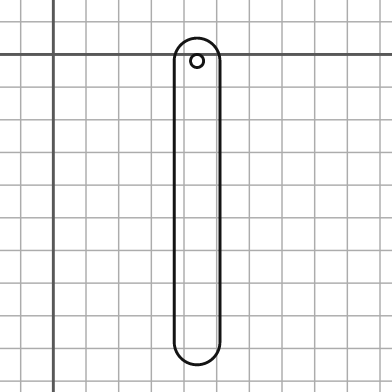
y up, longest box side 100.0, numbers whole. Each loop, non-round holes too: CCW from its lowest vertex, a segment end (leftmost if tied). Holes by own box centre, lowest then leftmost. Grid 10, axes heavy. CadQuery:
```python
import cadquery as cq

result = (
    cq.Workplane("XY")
    .moveTo(37.0, -88.0)
    .threePointArc((44.0, -95.0), (51.0, -88.0))
    .lineTo(51.0, -2.0)
    .threePointArc((44.0, 5.0), (37.0, -2.0))
    .close()
    .moveTo(44.0, -2.0)
    .circle(2.0)
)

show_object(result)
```